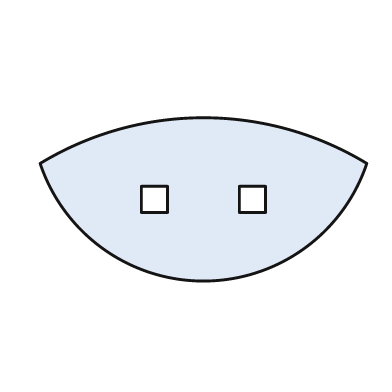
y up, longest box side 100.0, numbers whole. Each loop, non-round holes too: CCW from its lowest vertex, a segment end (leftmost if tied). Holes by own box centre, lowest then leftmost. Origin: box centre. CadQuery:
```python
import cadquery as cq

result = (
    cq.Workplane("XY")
    .moveTo(-50.0, 11.0)
    .threePointArc((0.0, -25.0), (50.0, 11.0))
    .threePointArc((0.0, 25.0), (-50.0, 11.0))
    .close()
    .moveTo(-19.0, -4.0)
    .lineTo(-11.0, -4.0)
    .lineTo(-11.0, 4.0)
    .lineTo(-19.0, 4.0)
    .close()
    .moveTo(11.0, -4.0)
    .lineTo(19.0, -4.0)
    .lineTo(19.0, 4.0)
    .lineTo(11.0, 4.0)
    .close()
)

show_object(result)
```